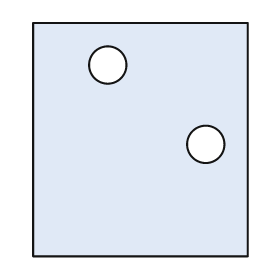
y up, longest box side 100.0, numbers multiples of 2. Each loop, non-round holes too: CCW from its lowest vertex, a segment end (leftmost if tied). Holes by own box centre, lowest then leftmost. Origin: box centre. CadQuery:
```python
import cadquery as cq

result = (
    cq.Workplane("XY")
    .moveTo(-46.0, -50.0)
    .lineTo(46.0, -50.0)
    .lineTo(46.0, 50.0)
    .lineTo(-46.0, 50.0)
    .close()
    .moveTo(28.0, -2.0)
    .circle(8.0)
    .moveTo(-14.0, 32.0)
    .circle(8.0)
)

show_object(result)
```